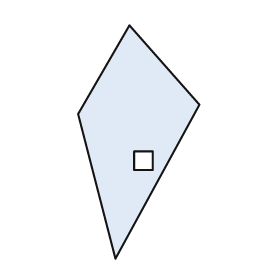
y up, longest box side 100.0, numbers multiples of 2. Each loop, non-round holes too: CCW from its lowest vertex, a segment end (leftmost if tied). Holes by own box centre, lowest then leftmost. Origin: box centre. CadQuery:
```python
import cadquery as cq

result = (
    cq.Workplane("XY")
    .moveTo(-10.0, -50.0)
    .lineTo(26.0, 16.0)
    .lineTo(-4.0, 50.0)
    .lineTo(-26.0, 12.0)
    .close()
    .moveTo(-2.0, -12.0)
    .lineTo(6.0, -12.0)
    .lineTo(6.0, -4.0)
    .lineTo(-2.0, -4.0)
    .close()
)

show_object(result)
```